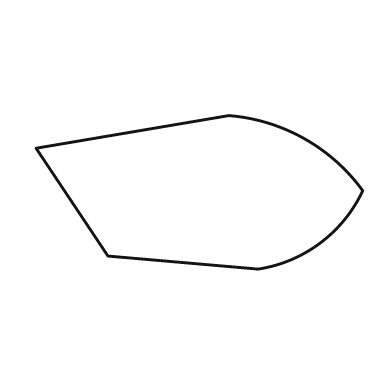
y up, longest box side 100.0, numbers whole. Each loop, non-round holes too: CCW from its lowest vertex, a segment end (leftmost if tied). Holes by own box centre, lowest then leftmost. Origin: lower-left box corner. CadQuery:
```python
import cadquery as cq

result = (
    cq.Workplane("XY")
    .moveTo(68.0, 0.0)
    .threePointArc((87.0, 8.0), (100.0, 24.0))
    .threePointArc((82.0, 40.0), (59.0, 47.0))
    .lineTo(0.0, 37.0)
    .lineTo(22.0, 4.0)
    .close()
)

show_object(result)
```